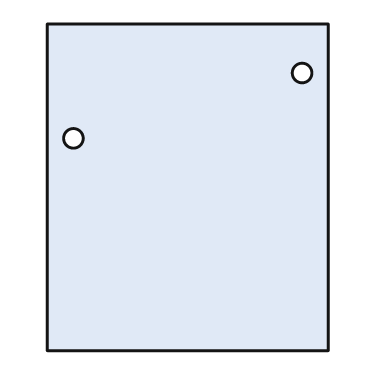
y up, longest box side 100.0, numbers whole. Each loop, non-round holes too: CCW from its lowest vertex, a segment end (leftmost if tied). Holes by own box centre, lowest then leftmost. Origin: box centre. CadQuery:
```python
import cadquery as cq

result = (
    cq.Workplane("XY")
    .moveTo(-43.0, -50.0)
    .lineTo(43.0, -50.0)
    .lineTo(43.0, 50.0)
    .lineTo(-43.0, 50.0)
    .close()
    .moveTo(-35.0, 15.0)
    .circle(3.0)
    .moveTo(35.0, 35.0)
    .circle(3.0)
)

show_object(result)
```